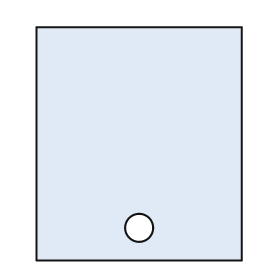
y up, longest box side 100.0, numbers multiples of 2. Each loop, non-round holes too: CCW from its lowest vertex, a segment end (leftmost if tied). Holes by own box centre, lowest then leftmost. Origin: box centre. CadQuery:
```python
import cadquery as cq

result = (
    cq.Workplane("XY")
    .moveTo(-44.0, -50.0)
    .lineTo(44.0, -50.0)
    .lineTo(44.0, 50.0)
    .lineTo(-44.0, 50.0)
    .close()
    .moveTo(0.0, -36.0)
    .circle(6.0)
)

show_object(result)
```